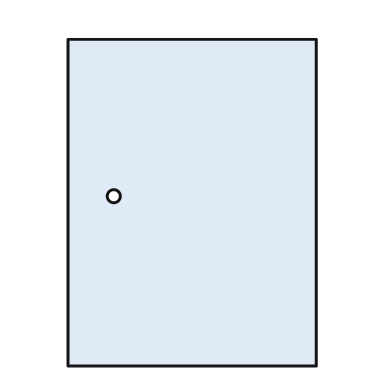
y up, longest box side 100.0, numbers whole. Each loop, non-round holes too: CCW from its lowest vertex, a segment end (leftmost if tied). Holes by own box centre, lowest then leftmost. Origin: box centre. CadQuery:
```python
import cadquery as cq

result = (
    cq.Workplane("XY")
    .moveTo(-38.0, -50.0)
    .lineTo(38.0, -50.0)
    .lineTo(38.0, 50.0)
    .lineTo(-38.0, 50.0)
    .close()
    .moveTo(-24.0, 2.0)
    .circle(2.0)
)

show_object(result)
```